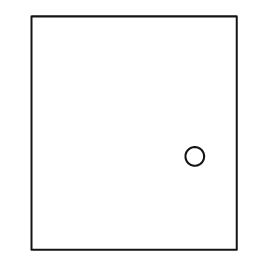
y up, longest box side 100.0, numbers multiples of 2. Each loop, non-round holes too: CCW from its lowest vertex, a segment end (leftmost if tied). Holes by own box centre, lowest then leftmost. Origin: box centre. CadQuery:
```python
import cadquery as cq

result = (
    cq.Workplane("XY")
    .moveTo(-44.0, -50.0)
    .lineTo(44.0, -50.0)
    .lineTo(44.0, 50.0)
    .lineTo(-44.0, 50.0)
    .close()
    .moveTo(26.0, -10.0)
    .circle(4.0)
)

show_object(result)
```